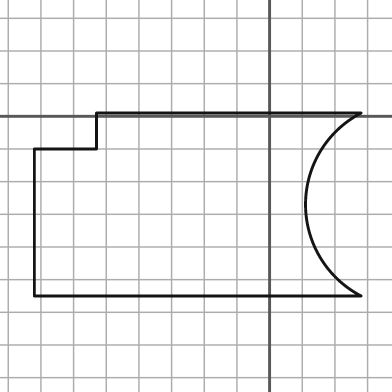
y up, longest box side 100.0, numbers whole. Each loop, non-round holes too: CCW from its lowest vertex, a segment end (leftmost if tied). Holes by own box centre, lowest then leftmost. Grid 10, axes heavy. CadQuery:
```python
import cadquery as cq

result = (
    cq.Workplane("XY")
    .moveTo(-72.0, -55.0)
    .lineTo(28.0, -55.0)
    .threePointArc((11.0, -27.0), (28.0, 1.0))
    .lineTo(-53.0, 1.0)
    .lineTo(-53.0, -10.0)
    .lineTo(-72.0, -10.0)
    .close()
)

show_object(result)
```